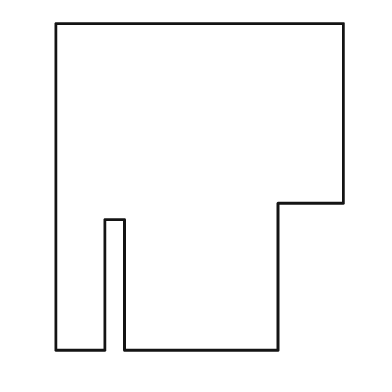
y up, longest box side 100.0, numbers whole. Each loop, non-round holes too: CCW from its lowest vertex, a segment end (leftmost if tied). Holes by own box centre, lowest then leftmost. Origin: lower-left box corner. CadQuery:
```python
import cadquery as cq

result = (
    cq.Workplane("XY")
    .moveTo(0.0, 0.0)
    .lineTo(15.0, 0.0)
    .lineTo(15.0, 40.0)
    .lineTo(21.0, 40.0)
    .lineTo(21.0, 0.0)
    .lineTo(68.0, 0.0)
    .lineTo(68.0, 45.0)
    .lineTo(88.0, 45.0)
    .lineTo(88.0, 100.0)
    .lineTo(0.0, 100.0)
    .close()
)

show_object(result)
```